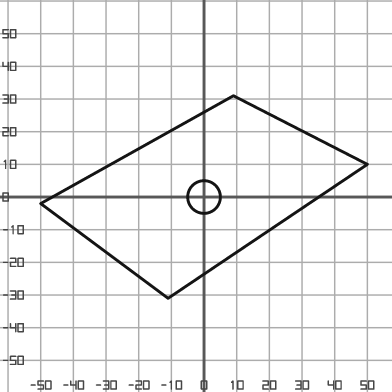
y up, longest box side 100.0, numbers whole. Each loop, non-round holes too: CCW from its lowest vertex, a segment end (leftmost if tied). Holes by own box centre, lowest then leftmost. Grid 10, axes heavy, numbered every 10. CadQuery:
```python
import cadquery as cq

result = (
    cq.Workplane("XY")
    .moveTo(-11.0, -31.0)
    .lineTo(50.0, 10.0)
    .lineTo(9.0, 31.0)
    .lineTo(-50.0, -2.0)
    .close()
    .moveTo(0.0, 0.0)
    .circle(5.0)
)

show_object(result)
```